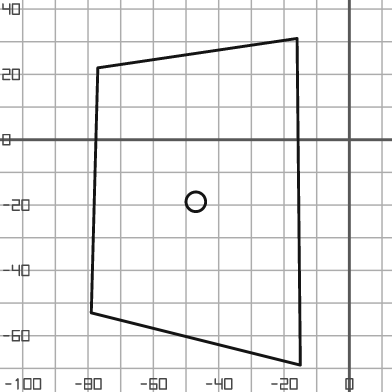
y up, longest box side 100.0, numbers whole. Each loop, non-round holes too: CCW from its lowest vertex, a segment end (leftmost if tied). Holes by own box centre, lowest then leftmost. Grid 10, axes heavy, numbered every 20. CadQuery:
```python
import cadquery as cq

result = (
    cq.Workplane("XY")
    .moveTo(-15.0, -69.0)
    .lineTo(-16.0, 31.0)
    .lineTo(-77.0, 22.0)
    .lineTo(-79.0, -53.0)
    .close()
    .moveTo(-47.0, -19.0)
    .circle(3.0)
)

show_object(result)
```